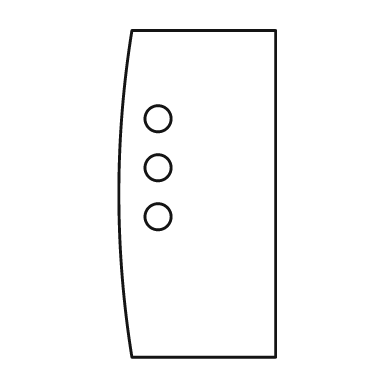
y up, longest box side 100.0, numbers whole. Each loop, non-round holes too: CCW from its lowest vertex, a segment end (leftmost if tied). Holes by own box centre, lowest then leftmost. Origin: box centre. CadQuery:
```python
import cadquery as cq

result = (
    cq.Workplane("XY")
    .moveTo(-20.0, -50.0)
    .lineTo(24.0, -50.0)
    .lineTo(24.0, 50.0)
    .lineTo(-20.0, 50.0)
    .threePointArc((-24.0, 0.0), (-20.0, -50.0))
    .close()
    .moveTo(-12.0, -7.0)
    .circle(4.0)
    .moveTo(-12.0, 8.0)
    .circle(4.0)
    .moveTo(-12.0, 23.0)
    .circle(4.0)
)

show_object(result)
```